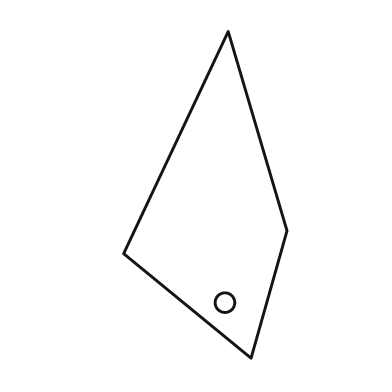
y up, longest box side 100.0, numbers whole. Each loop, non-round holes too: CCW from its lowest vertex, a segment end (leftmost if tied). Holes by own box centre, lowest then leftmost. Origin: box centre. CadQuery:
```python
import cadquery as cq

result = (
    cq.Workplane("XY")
    .moveTo(14.0, -50.0)
    .lineTo(25.0, -11.0)
    .lineTo(7.0, 50.0)
    .lineTo(-25.0, -18.0)
    .close()
    .moveTo(6.0, -33.0)
    .circle(3.0)
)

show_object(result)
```